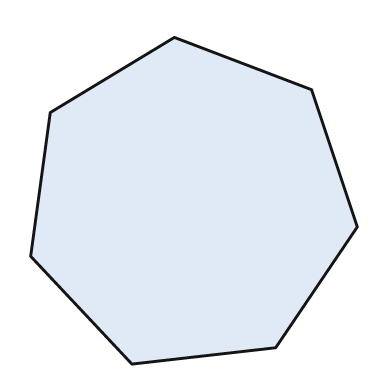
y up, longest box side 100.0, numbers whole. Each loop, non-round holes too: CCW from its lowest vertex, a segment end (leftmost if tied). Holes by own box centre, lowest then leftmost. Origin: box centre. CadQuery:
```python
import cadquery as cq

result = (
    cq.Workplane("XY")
    .moveTo(-19.0, -50.0)
    .lineTo(25.0, -45.0)
    .lineTo(50.0, -8.0)
    .lineTo(36.0, 34.0)
    .lineTo(-6.0, 50.0)
    .lineTo(-44.0, 27.0)
    .lineTo(-50.0, -17.0)
    .close()
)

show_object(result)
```